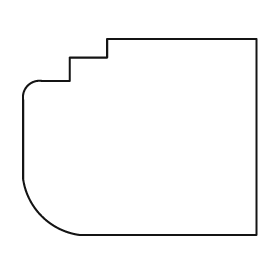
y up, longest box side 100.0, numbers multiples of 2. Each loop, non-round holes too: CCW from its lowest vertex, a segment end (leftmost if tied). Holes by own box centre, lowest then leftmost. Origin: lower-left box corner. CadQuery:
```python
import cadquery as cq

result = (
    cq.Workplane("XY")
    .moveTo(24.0, 0.0)
    .lineTo(100.0, 0.0)
    .lineTo(100.0, 84.0)
    .lineTo(36.0, 84.0)
    .lineTo(36.0, 76.0)
    .lineTo(20.0, 76.0)
    .lineTo(20.0, 66.0)
    .lineTo(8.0, 66.0)
    .threePointArc((2.0, 64.0), (0.0, 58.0))
    .lineTo(0.0, 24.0)
    .threePointArc((8.0, 8.0), (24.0, 0.0))
    .close()
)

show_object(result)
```